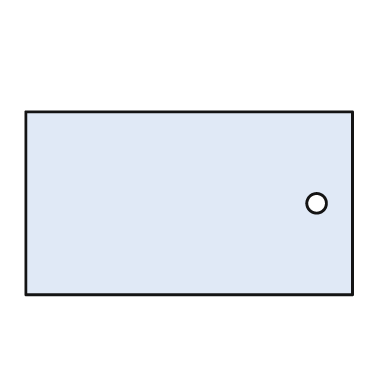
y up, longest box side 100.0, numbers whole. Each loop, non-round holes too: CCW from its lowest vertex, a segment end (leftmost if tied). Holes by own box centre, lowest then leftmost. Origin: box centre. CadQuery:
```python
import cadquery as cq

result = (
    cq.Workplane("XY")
    .moveTo(-50.0, -28.0)
    .lineTo(50.0, -28.0)
    .lineTo(50.0, 28.0)
    .lineTo(-50.0, 28.0)
    .close()
    .moveTo(39.0, 0.0)
    .circle(3.0)
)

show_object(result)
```